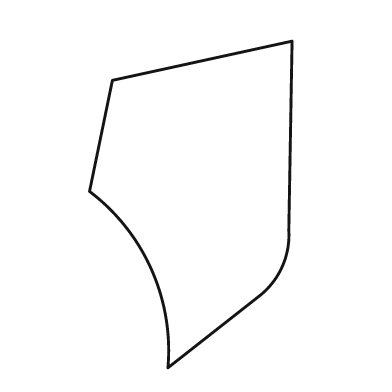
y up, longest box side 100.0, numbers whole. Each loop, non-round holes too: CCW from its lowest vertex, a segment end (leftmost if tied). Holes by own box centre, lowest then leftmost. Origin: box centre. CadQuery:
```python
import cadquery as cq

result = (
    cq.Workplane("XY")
    .moveTo(-7.0, -50.0)
    .lineTo(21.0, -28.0)
    .threePointArc((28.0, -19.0), (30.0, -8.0))
    .lineTo(31.0, 50.0)
    .lineTo(-24.0, 38.0)
    .lineTo(-31.0, 4.0)
    .threePointArc((-12.0, -20.0), (-7.0, -50.0))
    .close()
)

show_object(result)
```